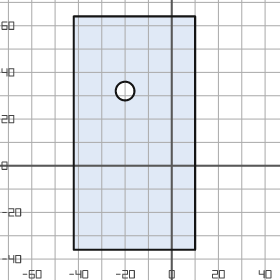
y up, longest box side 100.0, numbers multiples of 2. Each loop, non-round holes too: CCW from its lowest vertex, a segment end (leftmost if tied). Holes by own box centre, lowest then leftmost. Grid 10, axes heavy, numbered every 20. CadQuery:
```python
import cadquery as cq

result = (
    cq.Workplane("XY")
    .moveTo(-42.0, -36.0)
    .lineTo(10.0, -36.0)
    .lineTo(10.0, 64.0)
    .lineTo(-42.0, 64.0)
    .close()
    .moveTo(-20.0, 32.0)
    .circle(4.0)
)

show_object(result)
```